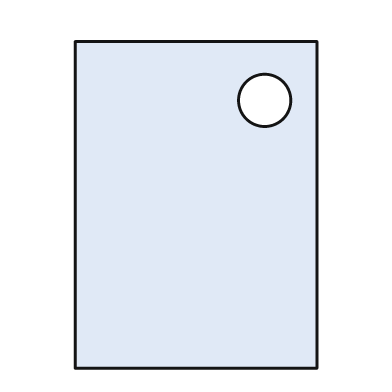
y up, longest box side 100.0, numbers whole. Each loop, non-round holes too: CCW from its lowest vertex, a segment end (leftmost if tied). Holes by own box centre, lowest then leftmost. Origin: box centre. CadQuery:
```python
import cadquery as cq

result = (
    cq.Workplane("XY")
    .moveTo(-37.0, -50.0)
    .lineTo(37.0, -50.0)
    .lineTo(37.0, 50.0)
    .lineTo(-37.0, 50.0)
    .close()
    .moveTo(21.0, 32.0)
    .circle(8.0)
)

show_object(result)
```